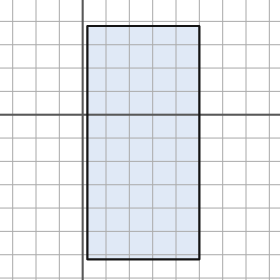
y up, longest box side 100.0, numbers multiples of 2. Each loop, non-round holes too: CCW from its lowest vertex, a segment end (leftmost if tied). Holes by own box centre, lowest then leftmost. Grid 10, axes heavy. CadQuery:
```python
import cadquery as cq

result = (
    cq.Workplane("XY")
    .moveTo(2.0, -62.0)
    .lineTo(50.0, -62.0)
    .lineTo(50.0, 38.0)
    .lineTo(2.0, 38.0)
    .close()
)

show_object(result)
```